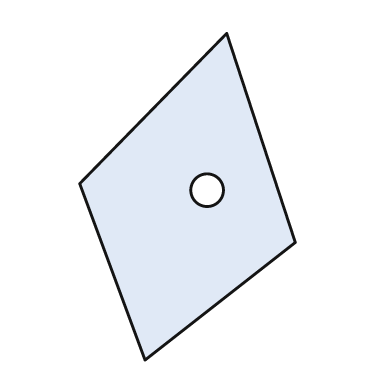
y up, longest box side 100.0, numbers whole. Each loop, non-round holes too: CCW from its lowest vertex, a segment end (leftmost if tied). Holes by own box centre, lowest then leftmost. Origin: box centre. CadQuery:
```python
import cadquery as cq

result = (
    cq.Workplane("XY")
    .moveTo(-13.0, -50.0)
    .lineTo(33.0, -14.0)
    .lineTo(12.0, 50.0)
    .lineTo(-33.0, 4.0)
    .close()
    .moveTo(6.0, 2.0)
    .circle(5.0)
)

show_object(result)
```